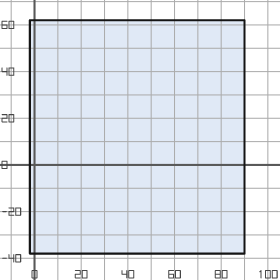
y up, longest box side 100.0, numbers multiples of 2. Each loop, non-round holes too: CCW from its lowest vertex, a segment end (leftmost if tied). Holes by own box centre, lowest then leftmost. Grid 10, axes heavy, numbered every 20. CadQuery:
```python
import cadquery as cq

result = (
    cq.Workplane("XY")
    .moveTo(-2.0, -38.0)
    .lineTo(90.0, -38.0)
    .lineTo(90.0, 62.0)
    .lineTo(-2.0, 62.0)
    .close()
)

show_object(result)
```